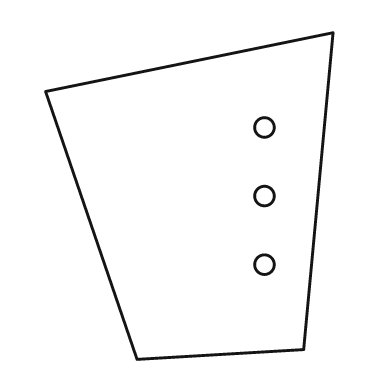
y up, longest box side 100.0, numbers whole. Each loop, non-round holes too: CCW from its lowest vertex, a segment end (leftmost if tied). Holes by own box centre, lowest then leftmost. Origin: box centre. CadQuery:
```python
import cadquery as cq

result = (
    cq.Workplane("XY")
    .moveTo(-16.0, -50.0)
    .lineTo(35.0, -47.0)
    .lineTo(44.0, 50.0)
    .lineTo(-44.0, 32.0)
    .close()
    .moveTo(23.0, -21.0)
    .circle(3.0)
    .moveTo(23.0, 0.0)
    .circle(3.0)
    .moveTo(23.0, 21.0)
    .circle(3.0)
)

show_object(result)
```